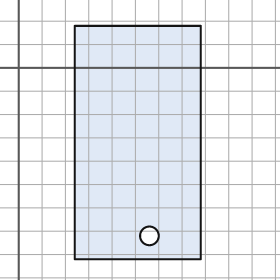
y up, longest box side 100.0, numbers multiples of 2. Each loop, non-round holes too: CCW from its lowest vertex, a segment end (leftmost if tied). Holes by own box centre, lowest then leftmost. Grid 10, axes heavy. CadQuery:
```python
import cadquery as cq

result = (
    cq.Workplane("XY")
    .moveTo(24.0, -82.0)
    .lineTo(78.0, -82.0)
    .lineTo(78.0, 18.0)
    .lineTo(24.0, 18.0)
    .close()
    .moveTo(56.0, -72.0)
    .circle(4.0)
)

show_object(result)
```